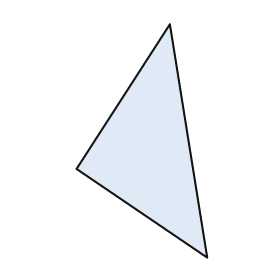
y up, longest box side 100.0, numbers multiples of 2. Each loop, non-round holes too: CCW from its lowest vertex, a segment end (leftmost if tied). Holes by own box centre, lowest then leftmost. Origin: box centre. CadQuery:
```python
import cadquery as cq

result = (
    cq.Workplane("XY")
    .moveTo(28.0, -50.0)
    .lineTo(12.0, 50.0)
    .lineTo(-28.0, -12.0)
    .close()
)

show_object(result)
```